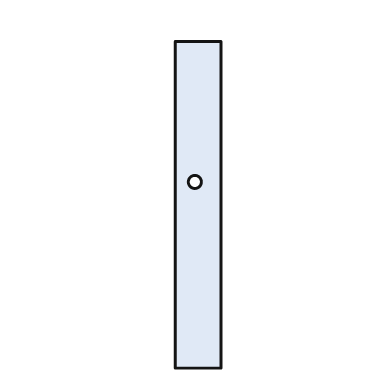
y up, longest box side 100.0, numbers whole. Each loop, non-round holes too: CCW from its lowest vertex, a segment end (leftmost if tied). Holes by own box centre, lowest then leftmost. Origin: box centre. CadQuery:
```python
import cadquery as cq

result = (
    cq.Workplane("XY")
    .moveTo(-7.0, -50.0)
    .lineTo(7.0, -50.0)
    .lineTo(7.0, 50.0)
    .lineTo(-7.0, 50.0)
    .close()
    .moveTo(-1.0, 7.0)
    .circle(2.0)
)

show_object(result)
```